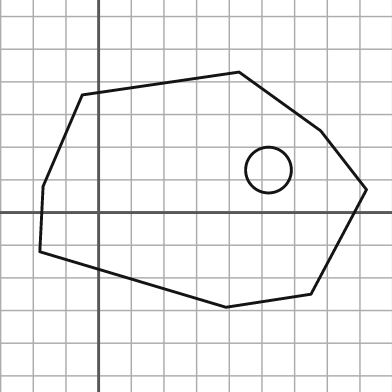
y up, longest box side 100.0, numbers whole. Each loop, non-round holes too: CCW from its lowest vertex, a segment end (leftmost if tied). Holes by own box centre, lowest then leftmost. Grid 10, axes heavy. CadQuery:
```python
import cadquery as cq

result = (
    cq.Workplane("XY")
    .moveTo(39.0, -29.0)
    .lineTo(65.0, -25.0)
    .lineTo(82.0, 7.0)
    .lineTo(68.0, 25.0)
    .lineTo(43.0, 43.0)
    .lineTo(-5.0, 36.0)
    .lineTo(-17.0, 8.0)
    .lineTo(-18.0, -12.0)
    .close()
    .moveTo(52.0, 13.0)
    .circle(7.0)
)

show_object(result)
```